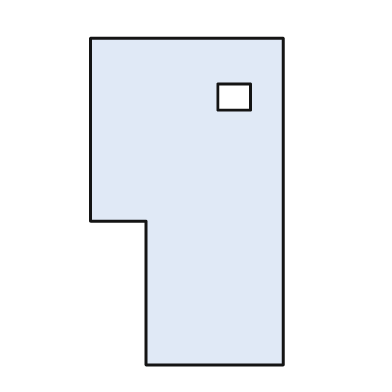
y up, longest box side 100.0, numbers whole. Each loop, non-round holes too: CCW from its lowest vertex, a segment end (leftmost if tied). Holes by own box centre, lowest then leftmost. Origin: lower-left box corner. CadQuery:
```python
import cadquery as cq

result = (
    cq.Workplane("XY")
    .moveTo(17.0, 0.0)
    .lineTo(59.0, 0.0)
    .lineTo(59.0, 100.0)
    .lineTo(0.0, 100.0)
    .lineTo(0.0, 44.0)
    .lineTo(17.0, 44.0)
    .close()
    .moveTo(39.0, 78.0)
    .lineTo(49.0, 78.0)
    .lineTo(49.0, 86.0)
    .lineTo(39.0, 86.0)
    .close()
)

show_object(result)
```